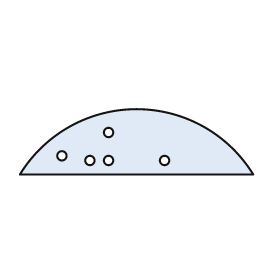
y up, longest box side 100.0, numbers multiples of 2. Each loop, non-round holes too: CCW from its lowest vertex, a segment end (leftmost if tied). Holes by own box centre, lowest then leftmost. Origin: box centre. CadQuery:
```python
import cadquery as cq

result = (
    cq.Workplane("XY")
    .moveTo(-50.0, -14.0)
    .lineTo(50.0, -14.0)
    .threePointArc((0.0, 14.0), (-50.0, -14.0))
    .close()
    .moveTo(-20.0, -8.0)
    .circle(2.0)
    .moveTo(-12.0, -8.0)
    .circle(2.0)
    .moveTo(12.0, -8.0)
    .circle(2.0)
    .moveTo(-32.0, -6.0)
    .circle(2.0)
    .moveTo(-12.0, 4.0)
    .circle(2.0)
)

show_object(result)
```